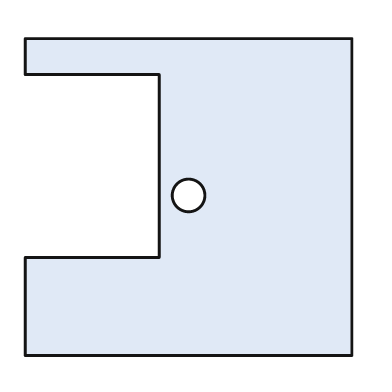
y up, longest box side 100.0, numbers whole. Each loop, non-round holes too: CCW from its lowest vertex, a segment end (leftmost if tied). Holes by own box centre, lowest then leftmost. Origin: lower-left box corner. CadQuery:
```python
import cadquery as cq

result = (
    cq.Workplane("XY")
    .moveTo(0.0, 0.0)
    .lineTo(100.0, 0.0)
    .lineTo(100.0, 97.0)
    .lineTo(0.0, 97.0)
    .lineTo(0.0, 86.0)
    .lineTo(41.0, 86.0)
    .lineTo(41.0, 30.0)
    .lineTo(0.0, 30.0)
    .close()
    .moveTo(50.0, 49.0)
    .circle(5.0)
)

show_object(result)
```